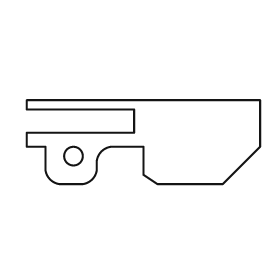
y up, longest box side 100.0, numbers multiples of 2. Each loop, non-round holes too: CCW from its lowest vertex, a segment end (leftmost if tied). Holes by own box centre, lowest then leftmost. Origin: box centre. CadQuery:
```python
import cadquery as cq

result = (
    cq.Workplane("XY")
    .moveTo(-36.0, -18.0)
    .lineTo(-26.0, -18.0)
    .threePointArc((-22.0, -16.0), (-20.0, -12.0))
    .lineTo(-20.0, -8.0)
    .threePointArc((-18.0, -4.0), (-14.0, -2.0))
    .lineTo(0.0, -2.0)
    .lineTo(0.0, -14.0)
    .lineTo(6.0, -18.0)
    .lineTo(34.0, -18.0)
    .lineTo(50.0, -2.0)
    .lineTo(50.0, 18.0)
    .lineTo(-50.0, 18.0)
    .lineTo(-50.0, 14.0)
    .lineTo(-4.0, 14.0)
    .lineTo(-4.0, 4.0)
    .lineTo(-50.0, 4.0)
    .lineTo(-50.0, -2.0)
    .lineTo(-42.0, -2.0)
    .lineTo(-42.0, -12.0)
    .threePointArc((-40.0, -16.0), (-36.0, -18.0))
    .close()
    .moveTo(-30.0, -6.0)
    .circle(4.0)
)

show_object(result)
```